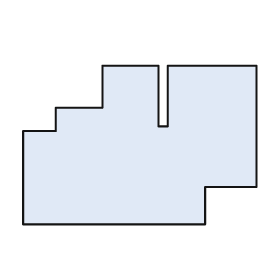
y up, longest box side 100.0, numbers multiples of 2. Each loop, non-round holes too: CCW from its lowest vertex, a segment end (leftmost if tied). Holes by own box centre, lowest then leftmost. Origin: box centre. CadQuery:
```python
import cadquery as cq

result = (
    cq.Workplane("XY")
    .moveTo(-50.0, -34.0)
    .lineTo(28.0, -34.0)
    .lineTo(28.0, -18.0)
    .lineTo(50.0, -18.0)
    .lineTo(50.0, 34.0)
    .lineTo(12.0, 34.0)
    .lineTo(12.0, 8.0)
    .lineTo(8.0, 8.0)
    .lineTo(8.0, 34.0)
    .lineTo(-16.0, 34.0)
    .lineTo(-16.0, 16.0)
    .lineTo(-36.0, 16.0)
    .lineTo(-36.0, 6.0)
    .lineTo(-50.0, 6.0)
    .close()
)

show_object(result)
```